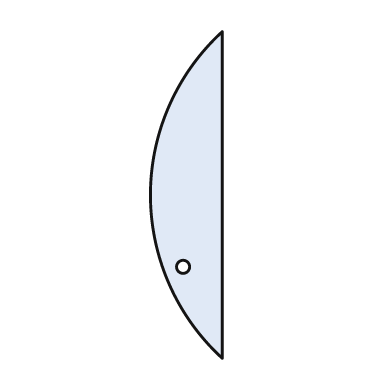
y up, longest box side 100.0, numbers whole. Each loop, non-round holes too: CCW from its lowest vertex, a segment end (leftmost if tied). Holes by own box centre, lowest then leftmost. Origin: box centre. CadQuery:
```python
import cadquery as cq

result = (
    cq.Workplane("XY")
    .moveTo(11.0, -50.0)
    .lineTo(11.0, 50.0)
    .threePointArc((-11.0, 0.0), (11.0, -50.0))
    .close()
    .moveTo(-1.0, -22.0)
    .circle(2.0)
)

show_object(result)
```